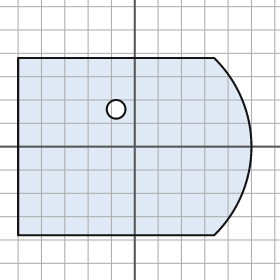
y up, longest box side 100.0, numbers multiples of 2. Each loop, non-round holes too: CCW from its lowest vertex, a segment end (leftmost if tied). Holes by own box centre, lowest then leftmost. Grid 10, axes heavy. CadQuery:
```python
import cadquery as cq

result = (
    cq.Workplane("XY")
    .moveTo(-50.0, -38.0)
    .lineTo(34.0, -38.0)
    .threePointArc((50.0, 0.0), (34.0, 38.0))
    .lineTo(-50.0, 38.0)
    .close()
    .moveTo(-8.0, 16.0)
    .circle(4.0)
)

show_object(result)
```